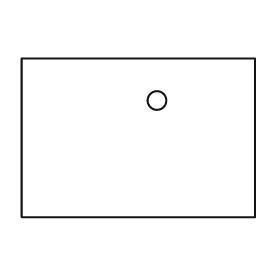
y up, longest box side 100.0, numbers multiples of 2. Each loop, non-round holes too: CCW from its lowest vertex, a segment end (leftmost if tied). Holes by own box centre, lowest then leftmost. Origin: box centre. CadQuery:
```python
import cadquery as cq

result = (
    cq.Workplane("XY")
    .moveTo(-50.0, -34.0)
    .lineTo(50.0, -34.0)
    .lineTo(50.0, 34.0)
    .lineTo(-50.0, 34.0)
    .close()
    .moveTo(8.0, 16.0)
    .circle(4.0)
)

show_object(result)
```